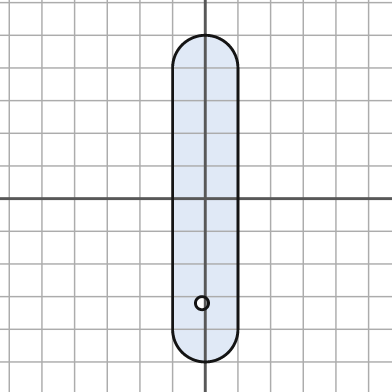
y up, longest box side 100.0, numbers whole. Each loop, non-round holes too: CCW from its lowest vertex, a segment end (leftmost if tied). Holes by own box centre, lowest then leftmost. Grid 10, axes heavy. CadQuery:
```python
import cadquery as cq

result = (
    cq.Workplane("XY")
    .moveTo(-10.0, -40.0)
    .threePointArc((0.0, -50.0), (10.0, -40.0))
    .lineTo(10.0, 40.0)
    .threePointArc((0.0, 50.0), (-10.0, 40.0))
    .close()
    .moveTo(-1.0, -32.0)
    .circle(2.0)
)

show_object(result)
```